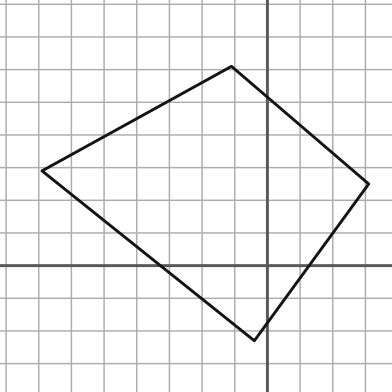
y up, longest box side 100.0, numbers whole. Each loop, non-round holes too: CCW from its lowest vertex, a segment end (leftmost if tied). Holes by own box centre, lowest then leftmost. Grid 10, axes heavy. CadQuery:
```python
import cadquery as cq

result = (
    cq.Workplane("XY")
    .moveTo(-4.0, -23.0)
    .lineTo(31.0, 25.0)
    .lineTo(-11.0, 61.0)
    .lineTo(-69.0, 29.0)
    .close()
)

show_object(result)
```